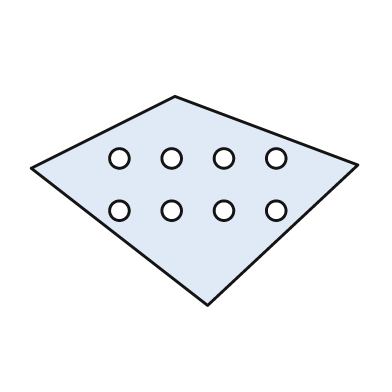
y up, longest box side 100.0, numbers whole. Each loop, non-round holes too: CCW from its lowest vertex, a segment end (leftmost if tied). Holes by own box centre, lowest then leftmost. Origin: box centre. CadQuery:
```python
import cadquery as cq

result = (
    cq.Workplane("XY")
    .moveTo(4.0, -32.0)
    .lineTo(50.0, 11.0)
    .lineTo(-6.0, 32.0)
    .lineTo(-50.0, 10.0)
    .close()
    .moveTo(-23.0, -3.0)
    .circle(3.0)
    .moveTo(-7.0, -3.0)
    .circle(3.0)
    .moveTo(9.0, -3.0)
    .circle(3.0)
    .moveTo(25.0, -3.0)
    .circle(3.0)
    .moveTo(-23.0, 13.0)
    .circle(3.0)
    .moveTo(-7.0, 13.0)
    .circle(3.0)
    .moveTo(9.0, 13.0)
    .circle(3.0)
    .moveTo(25.0, 13.0)
    .circle(3.0)
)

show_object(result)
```